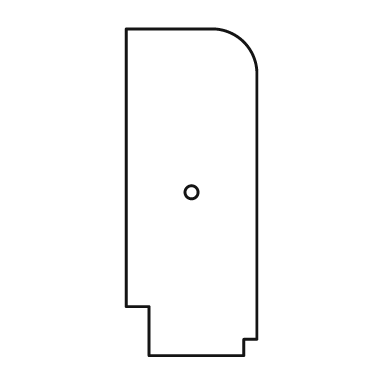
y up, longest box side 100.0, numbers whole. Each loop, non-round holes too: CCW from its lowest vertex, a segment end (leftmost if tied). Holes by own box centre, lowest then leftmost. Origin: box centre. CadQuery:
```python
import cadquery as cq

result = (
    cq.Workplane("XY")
    .moveTo(-13.0, -50.0)
    .lineTo(16.0, -50.0)
    .lineTo(16.0, -45.0)
    .lineTo(20.0, -45.0)
    .lineTo(20.0, 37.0)
    .threePointArc((16.0, 46.0), (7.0, 50.0))
    .lineTo(-20.0, 50.0)
    .lineTo(-20.0, -35.0)
    .lineTo(-13.0, -35.0)
    .close()
    .moveTo(0.0, 0.0)
    .circle(2.0)
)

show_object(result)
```